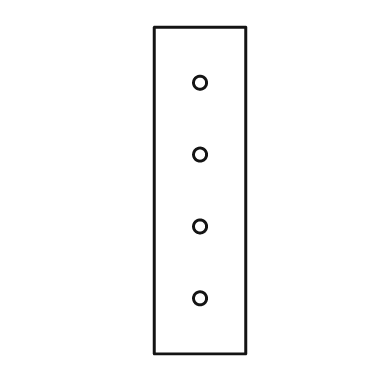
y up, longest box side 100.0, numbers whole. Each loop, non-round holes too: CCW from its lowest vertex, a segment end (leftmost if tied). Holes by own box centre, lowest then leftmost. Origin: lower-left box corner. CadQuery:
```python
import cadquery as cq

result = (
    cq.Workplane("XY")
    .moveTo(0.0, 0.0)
    .lineTo(28.0, 0.0)
    .lineTo(28.0, 100.0)
    .lineTo(0.0, 100.0)
    .close()
    .moveTo(14.0, 17.0)
    .circle(2.0)
    .moveTo(14.0, 39.0)
    .circle(2.0)
    .moveTo(14.0, 61.0)
    .circle(2.0)
    .moveTo(14.0, 83.0)
    .circle(2.0)
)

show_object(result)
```